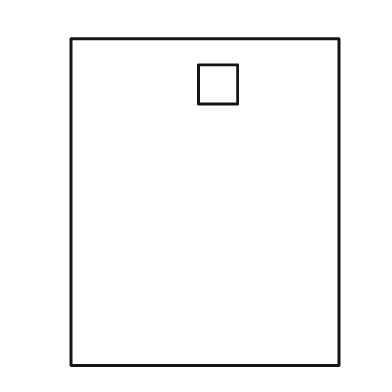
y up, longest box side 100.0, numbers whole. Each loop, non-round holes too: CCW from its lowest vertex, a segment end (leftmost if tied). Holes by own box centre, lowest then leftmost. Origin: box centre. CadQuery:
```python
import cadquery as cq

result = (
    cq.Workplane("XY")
    .moveTo(-41.0, -50.0)
    .lineTo(41.0, -50.0)
    .lineTo(41.0, 50.0)
    .lineTo(-41.0, 50.0)
    .close()
    .moveTo(-2.0, 30.0)
    .lineTo(10.0, 30.0)
    .lineTo(10.0, 42.0)
    .lineTo(-2.0, 42.0)
    .close()
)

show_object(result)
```